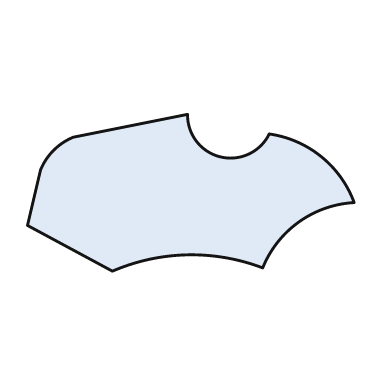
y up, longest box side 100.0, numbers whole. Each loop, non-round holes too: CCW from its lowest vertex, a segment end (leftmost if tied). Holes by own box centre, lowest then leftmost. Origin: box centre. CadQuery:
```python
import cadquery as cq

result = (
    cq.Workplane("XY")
    .moveTo(-24.0, -24.0)
    .threePointArc((-1.0, -19.0), (22.0, -23.0))
    .threePointArc((33.0, -9.0), (50.0, -3.0))
    .threePointArc((40.0, 11.0), (24.0, 18.0))
    .threePointArc((9.0, 11.0), (-1.0, 24.0))
    .lineTo(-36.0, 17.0)
    .threePointArc((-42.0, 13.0), (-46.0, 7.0))
    .lineTo(-50.0, -10.0)
    .close()
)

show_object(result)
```